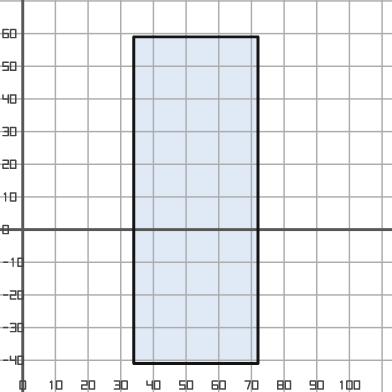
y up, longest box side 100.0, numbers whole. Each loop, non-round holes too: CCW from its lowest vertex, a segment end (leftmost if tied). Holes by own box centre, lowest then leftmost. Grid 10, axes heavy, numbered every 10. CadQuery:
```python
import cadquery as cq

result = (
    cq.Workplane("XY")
    .moveTo(34.0, -41.0)
    .lineTo(72.0, -41.0)
    .lineTo(72.0, 59.0)
    .lineTo(34.0, 59.0)
    .close()
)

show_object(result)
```